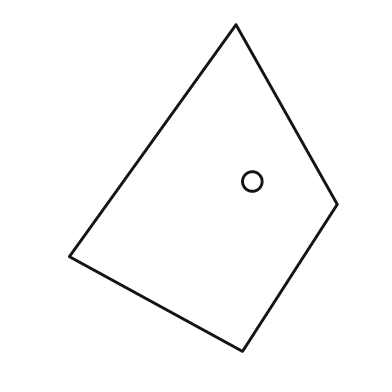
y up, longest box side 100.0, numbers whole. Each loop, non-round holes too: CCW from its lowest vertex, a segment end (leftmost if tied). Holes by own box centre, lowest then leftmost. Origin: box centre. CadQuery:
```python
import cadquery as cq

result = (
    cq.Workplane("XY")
    .moveTo(12.0, -50.0)
    .lineTo(41.0, -5.0)
    .lineTo(10.0, 50.0)
    .lineTo(-41.0, -21.0)
    .close()
    .moveTo(15.0, 2.0)
    .circle(3.0)
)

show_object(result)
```